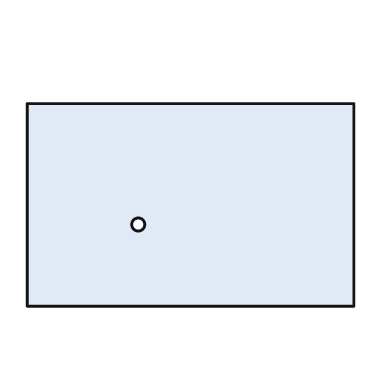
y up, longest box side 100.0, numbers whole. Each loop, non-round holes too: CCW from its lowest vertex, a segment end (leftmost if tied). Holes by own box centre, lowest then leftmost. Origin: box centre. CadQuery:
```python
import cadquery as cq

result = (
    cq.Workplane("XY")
    .moveTo(-50.0, -31.0)
    .lineTo(50.0, -31.0)
    .lineTo(50.0, 31.0)
    .lineTo(-50.0, 31.0)
    .close()
    .moveTo(-16.0, -6.0)
    .circle(2.0)
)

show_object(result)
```